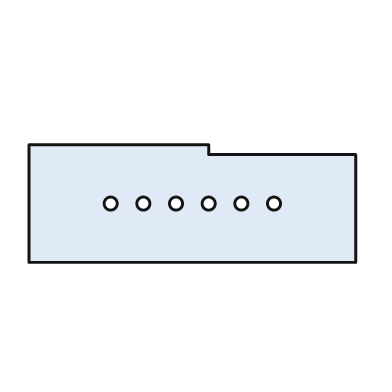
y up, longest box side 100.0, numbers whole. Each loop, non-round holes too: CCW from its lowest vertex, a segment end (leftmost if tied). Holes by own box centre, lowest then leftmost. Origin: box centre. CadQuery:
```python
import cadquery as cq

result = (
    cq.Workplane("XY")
    .moveTo(-50.0, -18.0)
    .lineTo(50.0, -18.0)
    .lineTo(50.0, 15.0)
    .lineTo(5.0, 15.0)
    .lineTo(5.0, 18.0)
    .lineTo(-50.0, 18.0)
    .close()
    .moveTo(-25.0, 0.0)
    .circle(2.0)
    .moveTo(-15.0, 0.0)
    .circle(2.0)
    .moveTo(-5.0, 0.0)
    .circle(2.0)
    .moveTo(5.0, 0.0)
    .circle(2.0)
    .moveTo(15.0, 0.0)
    .circle(2.0)
    .moveTo(25.0, 0.0)
    .circle(2.0)
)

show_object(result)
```